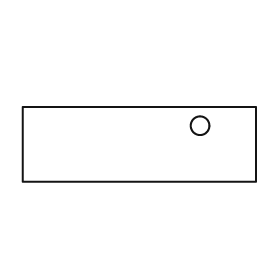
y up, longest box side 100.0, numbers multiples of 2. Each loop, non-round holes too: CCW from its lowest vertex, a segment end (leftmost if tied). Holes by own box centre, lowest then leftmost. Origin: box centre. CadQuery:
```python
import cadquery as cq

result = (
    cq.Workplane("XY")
    .moveTo(-50.0, -16.0)
    .lineTo(50.0, -16.0)
    .lineTo(50.0, 16.0)
    .lineTo(-50.0, 16.0)
    .close()
    .moveTo(26.0, 8.0)
    .circle(4.0)
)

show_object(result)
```